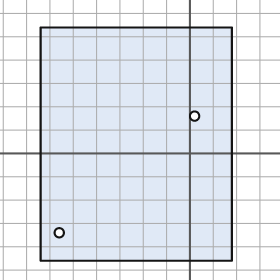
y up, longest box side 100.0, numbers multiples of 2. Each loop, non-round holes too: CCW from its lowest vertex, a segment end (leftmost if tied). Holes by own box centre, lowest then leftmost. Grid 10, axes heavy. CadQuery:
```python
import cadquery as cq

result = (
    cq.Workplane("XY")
    .moveTo(-64.0, -46.0)
    .lineTo(18.0, -46.0)
    .lineTo(18.0, 54.0)
    .lineTo(-64.0, 54.0)
    .close()
    .moveTo(-56.0, -34.0)
    .circle(2.0)
    .moveTo(2.0, 16.0)
    .circle(2.0)
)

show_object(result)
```